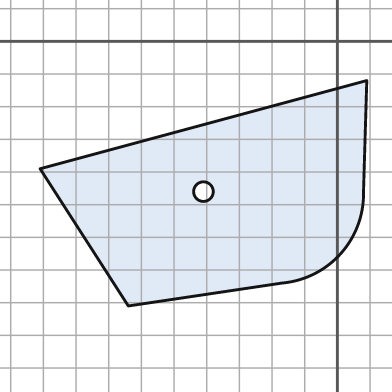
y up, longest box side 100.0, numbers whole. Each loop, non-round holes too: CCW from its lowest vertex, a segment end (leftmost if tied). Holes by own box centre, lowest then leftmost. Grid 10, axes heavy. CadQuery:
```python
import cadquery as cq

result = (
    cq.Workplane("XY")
    .moveTo(-64.0, -81.0)
    .lineTo(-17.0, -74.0)
    .threePointArc((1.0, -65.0), (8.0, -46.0))
    .lineTo(9.0, -12.0)
    .lineTo(-91.0, -39.0)
    .close()
    .moveTo(-41.0, -46.0)
    .circle(3.0)
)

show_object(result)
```